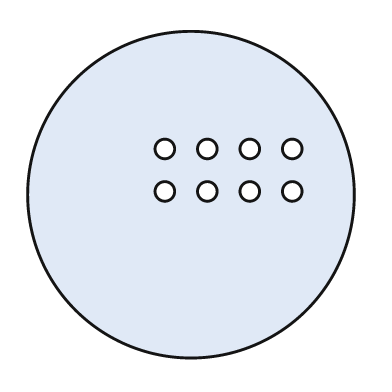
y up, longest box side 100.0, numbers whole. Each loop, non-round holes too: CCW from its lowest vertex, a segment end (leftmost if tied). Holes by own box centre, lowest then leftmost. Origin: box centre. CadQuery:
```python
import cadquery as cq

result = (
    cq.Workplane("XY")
    .moveTo(0.0, 0.0)
    .circle(50.0)
    .moveTo(-8.0, 1.0)
    .circle(3.0)
    .moveTo(5.0, 1.0)
    .circle(3.0)
    .moveTo(18.0, 1.0)
    .circle(3.0)
    .moveTo(31.0, 1.0)
    .circle(3.0)
    .moveTo(-8.0, 14.0)
    .circle(3.0)
    .moveTo(5.0, 14.0)
    .circle(3.0)
    .moveTo(18.0, 14.0)
    .circle(3.0)
    .moveTo(31.0, 14.0)
    .circle(3.0)
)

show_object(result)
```